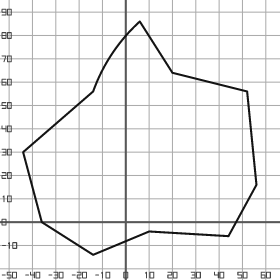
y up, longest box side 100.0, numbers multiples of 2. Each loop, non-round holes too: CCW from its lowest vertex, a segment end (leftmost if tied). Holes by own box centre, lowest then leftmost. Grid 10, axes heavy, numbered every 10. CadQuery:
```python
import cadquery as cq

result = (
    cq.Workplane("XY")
    .moveTo(-14.0, -14.0)
    .lineTo(10.0, -4.0)
    .lineTo(44.0, -6.0)
    .lineTo(56.0, 16.0)
    .lineTo(52.0, 56.0)
    .lineTo(20.0, 64.0)
    .lineTo(6.0, 86.0)
    .threePointArc((-6.0, 72.0), (-14.0, 56.0))
    .lineTo(-44.0, 30.0)
    .lineTo(-36.0, 0.0)
    .close()
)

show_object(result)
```